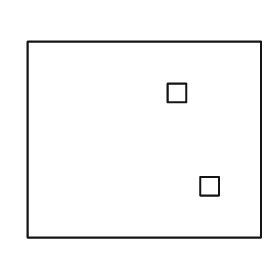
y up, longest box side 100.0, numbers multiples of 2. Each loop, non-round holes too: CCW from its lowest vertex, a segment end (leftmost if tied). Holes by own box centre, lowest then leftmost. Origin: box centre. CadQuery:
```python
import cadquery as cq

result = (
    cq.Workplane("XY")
    .moveTo(-50.0, -42.0)
    .lineTo(50.0, -42.0)
    .lineTo(50.0, 42.0)
    .lineTo(-50.0, 42.0)
    .close()
    .moveTo(24.0, -24.0)
    .lineTo(32.0, -24.0)
    .lineTo(32.0, -16.0)
    .lineTo(24.0, -16.0)
    .close()
    .moveTo(10.0, 16.0)
    .lineTo(18.0, 16.0)
    .lineTo(18.0, 24.0)
    .lineTo(10.0, 24.0)
    .close()
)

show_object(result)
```